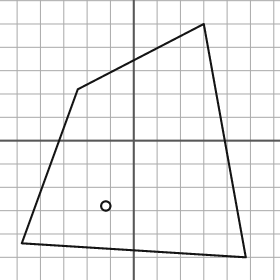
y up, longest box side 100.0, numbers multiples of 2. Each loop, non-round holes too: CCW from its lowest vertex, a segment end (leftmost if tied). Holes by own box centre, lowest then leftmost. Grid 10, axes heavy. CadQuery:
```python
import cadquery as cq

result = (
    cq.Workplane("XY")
    .moveTo(48.0, -50.0)
    .lineTo(30.0, 50.0)
    .lineTo(-24.0, 22.0)
    .lineTo(-48.0, -44.0)
    .close()
    .moveTo(-12.0, -28.0)
    .circle(2.0)
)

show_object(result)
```